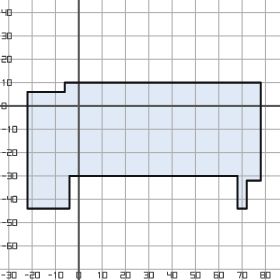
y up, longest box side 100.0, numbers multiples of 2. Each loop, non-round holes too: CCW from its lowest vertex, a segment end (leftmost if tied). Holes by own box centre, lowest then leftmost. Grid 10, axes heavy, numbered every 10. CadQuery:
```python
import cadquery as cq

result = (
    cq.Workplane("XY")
    .moveTo(-22.0, -44.0)
    .lineTo(-4.0, -44.0)
    .lineTo(-4.0, -30.0)
    .lineTo(68.0, -30.0)
    .lineTo(68.0, -44.0)
    .lineTo(72.0, -44.0)
    .lineTo(72.0, -32.0)
    .lineTo(78.0, -32.0)
    .lineTo(78.0, 10.0)
    .lineTo(-6.0, 10.0)
    .lineTo(-6.0, 6.0)
    .lineTo(-22.0, 6.0)
    .close()
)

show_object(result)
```